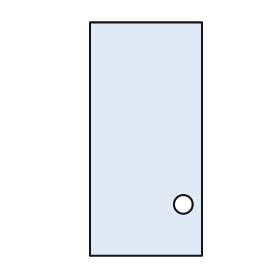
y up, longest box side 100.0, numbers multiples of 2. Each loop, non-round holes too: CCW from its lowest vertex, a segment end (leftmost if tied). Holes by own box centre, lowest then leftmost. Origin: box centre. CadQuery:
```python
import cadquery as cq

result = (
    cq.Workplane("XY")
    .moveTo(-24.0, -50.0)
    .lineTo(24.0, -50.0)
    .lineTo(24.0, 50.0)
    .lineTo(-24.0, 50.0)
    .close()
    .moveTo(16.0, -28.0)
    .circle(4.0)
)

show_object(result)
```